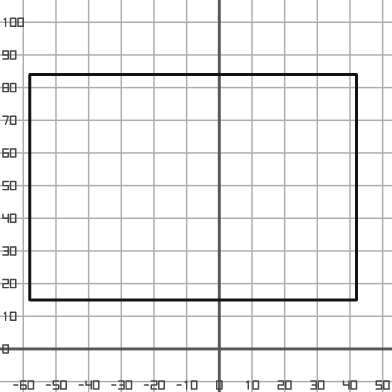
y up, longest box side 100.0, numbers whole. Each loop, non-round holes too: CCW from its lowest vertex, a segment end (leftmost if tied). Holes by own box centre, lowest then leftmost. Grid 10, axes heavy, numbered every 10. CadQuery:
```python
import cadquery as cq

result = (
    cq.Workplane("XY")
    .moveTo(-58.0, 15.0)
    .lineTo(42.0, 15.0)
    .lineTo(42.0, 84.0)
    .lineTo(-58.0, 84.0)
    .close()
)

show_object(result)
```